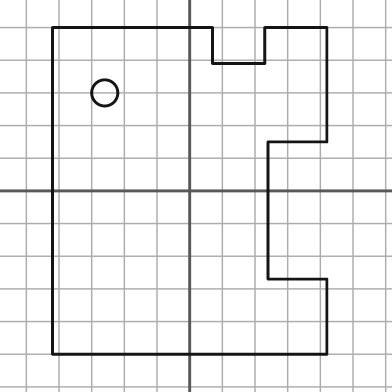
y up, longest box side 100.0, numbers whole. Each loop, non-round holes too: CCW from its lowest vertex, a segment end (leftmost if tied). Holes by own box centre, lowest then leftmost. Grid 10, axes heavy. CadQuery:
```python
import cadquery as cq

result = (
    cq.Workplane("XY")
    .moveTo(-42.0, -50.0)
    .lineTo(42.0, -50.0)
    .lineTo(42.0, -27.0)
    .lineTo(24.0, -27.0)
    .lineTo(24.0, 15.0)
    .lineTo(42.0, 15.0)
    .lineTo(42.0, 50.0)
    .lineTo(23.0, 50.0)
    .lineTo(23.0, 39.0)
    .lineTo(7.0, 39.0)
    .lineTo(7.0, 50.0)
    .lineTo(-42.0, 50.0)
    .close()
    .moveTo(-26.0, 30.0)
    .circle(4.0)
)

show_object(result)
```